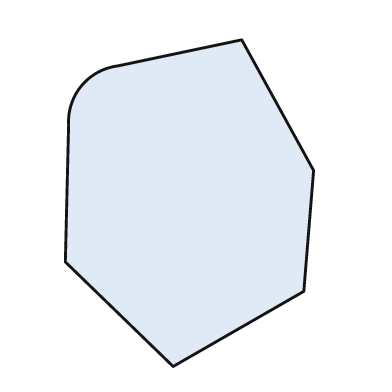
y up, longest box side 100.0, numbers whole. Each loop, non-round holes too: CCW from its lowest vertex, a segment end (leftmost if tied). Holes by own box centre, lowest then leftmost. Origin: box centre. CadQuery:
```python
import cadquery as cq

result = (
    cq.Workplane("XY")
    .moveTo(-5.0, -50.0)
    .lineTo(35.0, -27.0)
    .lineTo(38.0, 10.0)
    .lineTo(16.0, 50.0)
    .lineTo(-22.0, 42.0)
    .threePointArc((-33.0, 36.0), (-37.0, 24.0))
    .lineTo(-38.0, -18.0)
    .close()
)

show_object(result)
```